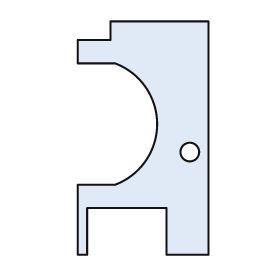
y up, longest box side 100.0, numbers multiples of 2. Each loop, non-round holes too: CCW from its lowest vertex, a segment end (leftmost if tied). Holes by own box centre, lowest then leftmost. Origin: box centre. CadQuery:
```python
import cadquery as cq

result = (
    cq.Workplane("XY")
    .moveTo(-28.0, -50.0)
    .lineTo(-24.0, -50.0)
    .lineTo(-24.0, -30.0)
    .lineTo(10.0, -30.0)
    .lineTo(10.0, -50.0)
    .lineTo(28.0, -50.0)
    .lineTo(28.0, 50.0)
    .lineTo(-14.0, 50.0)
    .lineTo(-14.0, 42.0)
    .lineTo(-28.0, 42.0)
    .lineTo(-28.0, 32.0)
    .lineTo(-12.0, 32.0)
    .threePointArc((6.0, 6.0), (-12.0, -20.0))
    .lineTo(-28.0, -20.0)
    .close()
    .moveTo(20.0, -6.0)
    .circle(4.0)
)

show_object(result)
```